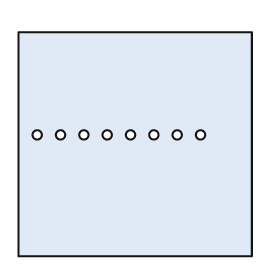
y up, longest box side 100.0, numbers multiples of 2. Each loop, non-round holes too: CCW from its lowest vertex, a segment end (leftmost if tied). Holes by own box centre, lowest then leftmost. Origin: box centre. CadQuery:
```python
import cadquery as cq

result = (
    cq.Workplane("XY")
    .moveTo(-50.0, -48.0)
    .lineTo(50.0, -48.0)
    .lineTo(50.0, 48.0)
    .lineTo(-50.0, 48.0)
    .close()
    .moveTo(-42.0, 4.0)
    .circle(2.0)
    .moveTo(-32.0, 4.0)
    .circle(2.0)
    .moveTo(-22.0, 4.0)
    .circle(2.0)
    .moveTo(-12.0, 4.0)
    .circle(2.0)
    .moveTo(-2.0, 4.0)
    .circle(2.0)
    .moveTo(8.0, 4.0)
    .circle(2.0)
    .moveTo(18.0, 4.0)
    .circle(2.0)
    .moveTo(28.0, 4.0)
    .circle(2.0)
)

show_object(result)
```